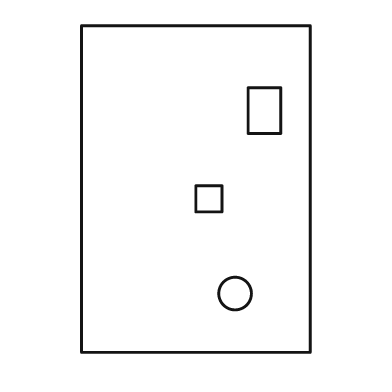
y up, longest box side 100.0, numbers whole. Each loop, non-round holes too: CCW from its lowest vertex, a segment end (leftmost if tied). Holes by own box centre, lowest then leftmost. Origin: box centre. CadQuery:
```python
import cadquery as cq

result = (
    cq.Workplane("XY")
    .moveTo(-35.0, -50.0)
    .lineTo(35.0, -50.0)
    .lineTo(35.0, 50.0)
    .lineTo(-35.0, 50.0)
    .close()
    .moveTo(12.0, -32.0)
    .circle(5.0)
    .moveTo(0.0, -7.0)
    .lineTo(8.0, -7.0)
    .lineTo(8.0, 1.0)
    .lineTo(0.0, 1.0)
    .close()
    .moveTo(16.0, 17.0)
    .lineTo(26.0, 17.0)
    .lineTo(26.0, 31.0)
    .lineTo(16.0, 31.0)
    .close()
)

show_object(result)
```